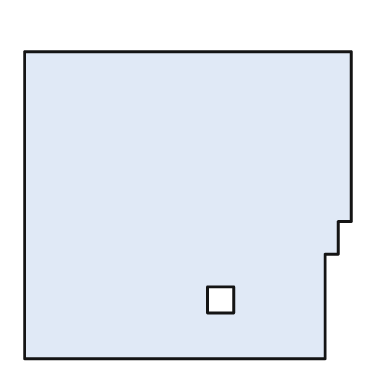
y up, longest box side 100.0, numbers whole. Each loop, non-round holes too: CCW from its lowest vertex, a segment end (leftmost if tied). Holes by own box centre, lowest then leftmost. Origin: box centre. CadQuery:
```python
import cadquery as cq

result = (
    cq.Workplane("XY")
    .moveTo(-50.0, -47.0)
    .lineTo(42.0, -47.0)
    .lineTo(42.0, -15.0)
    .lineTo(46.0, -15.0)
    .lineTo(46.0, -5.0)
    .lineTo(50.0, -5.0)
    .lineTo(50.0, 47.0)
    .lineTo(-50.0, 47.0)
    .close()
    .moveTo(6.0, -33.0)
    .lineTo(14.0, -33.0)
    .lineTo(14.0, -25.0)
    .lineTo(6.0, -25.0)
    .close()
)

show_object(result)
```